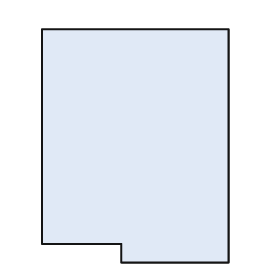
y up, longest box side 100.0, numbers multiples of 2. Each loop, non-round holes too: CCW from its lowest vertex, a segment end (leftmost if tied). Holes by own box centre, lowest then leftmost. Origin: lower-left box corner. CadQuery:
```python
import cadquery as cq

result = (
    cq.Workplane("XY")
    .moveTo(34.0, 0.0)
    .lineTo(80.0, 0.0)
    .lineTo(80.0, 100.0)
    .lineTo(0.0, 100.0)
    .lineTo(0.0, 8.0)
    .lineTo(34.0, 8.0)
    .close()
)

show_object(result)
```